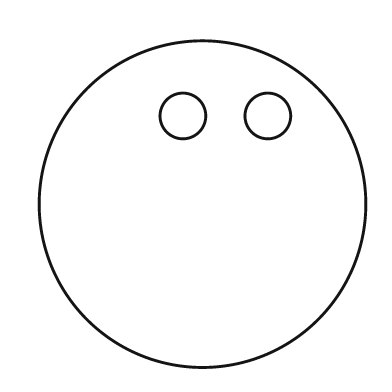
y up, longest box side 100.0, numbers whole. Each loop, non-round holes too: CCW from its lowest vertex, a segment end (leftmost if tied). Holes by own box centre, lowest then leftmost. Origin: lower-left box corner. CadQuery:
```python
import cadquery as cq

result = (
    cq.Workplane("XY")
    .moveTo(50.0, 50.0)
    .circle(50.0)
    .moveTo(44.0, 77.0)
    .circle(7.0)
    .moveTo(70.0, 77.0)
    .circle(7.0)
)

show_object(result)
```